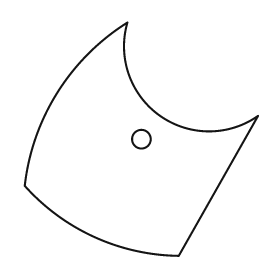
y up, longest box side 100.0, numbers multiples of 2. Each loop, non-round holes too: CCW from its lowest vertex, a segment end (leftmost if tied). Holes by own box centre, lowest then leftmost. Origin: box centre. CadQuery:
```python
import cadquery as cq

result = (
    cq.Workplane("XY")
    .moveTo(16.0, -50.0)
    .lineTo(50.0, 10.0)
    .threePointArc((8.0, 10.0), (-6.0, 50.0))
    .threePointArc((-36.0, 20.0), (-50.0, -20.0))
    .threePointArc((-20.0, -42.0), (16.0, -50.0))
    .close()
    .moveTo(0.0, 0.0)
    .circle(4.0)
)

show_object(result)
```